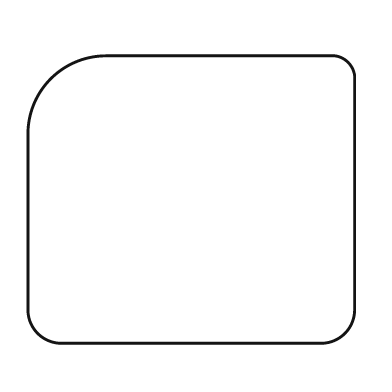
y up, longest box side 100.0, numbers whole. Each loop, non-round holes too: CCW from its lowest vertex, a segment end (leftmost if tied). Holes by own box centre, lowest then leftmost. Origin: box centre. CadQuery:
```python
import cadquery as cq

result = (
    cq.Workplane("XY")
    .moveTo(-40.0, -44.0)
    .lineTo(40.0, -44.0)
    .threePointArc((47.0, -41.0), (50.0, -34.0))
    .lineTo(50.0, 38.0)
    .threePointArc((48.0, 42.0), (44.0, 44.0))
    .lineTo(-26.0, 44.0)
    .threePointArc((-43.0, 37.0), (-50.0, 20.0))
    .lineTo(-50.0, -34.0)
    .threePointArc((-47.0, -41.0), (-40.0, -44.0))
    .close()
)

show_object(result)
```